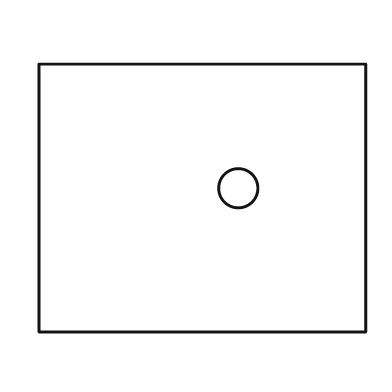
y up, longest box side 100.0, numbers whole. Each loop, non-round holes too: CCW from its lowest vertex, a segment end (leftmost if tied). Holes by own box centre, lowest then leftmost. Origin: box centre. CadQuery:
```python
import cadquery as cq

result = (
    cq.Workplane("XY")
    .moveTo(-50.0, -41.0)
    .lineTo(50.0, -41.0)
    .lineTo(50.0, 41.0)
    .lineTo(-50.0, 41.0)
    .close()
    .moveTo(11.0, 3.0)
    .circle(6.0)
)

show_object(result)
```